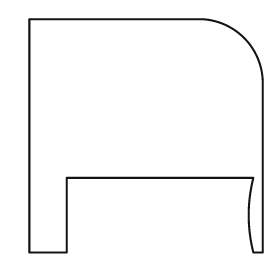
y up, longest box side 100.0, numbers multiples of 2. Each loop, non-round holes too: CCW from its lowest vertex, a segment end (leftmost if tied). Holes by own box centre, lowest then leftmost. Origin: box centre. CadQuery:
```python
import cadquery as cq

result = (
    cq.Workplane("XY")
    .moveTo(-50.0, -50.0)
    .lineTo(-34.0, -50.0)
    .lineTo(-34.0, -18.0)
    .lineTo(46.0, -18.0)
    .threePointArc((44.0, -34.0), (46.0, -50.0))
    .lineTo(50.0, -50.0)
    .lineTo(50.0, 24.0)
    .threePointArc((42.0, 42.0), (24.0, 50.0))
    .lineTo(-50.0, 50.0)
    .close()
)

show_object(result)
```